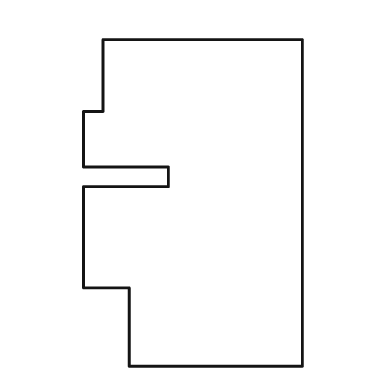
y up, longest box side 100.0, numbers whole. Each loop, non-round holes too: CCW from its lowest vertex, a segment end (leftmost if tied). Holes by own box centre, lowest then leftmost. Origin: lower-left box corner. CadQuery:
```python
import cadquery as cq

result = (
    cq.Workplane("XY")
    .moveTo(14.0, 0.0)
    .lineTo(67.0, 0.0)
    .lineTo(67.0, 100.0)
    .lineTo(6.0, 100.0)
    .lineTo(6.0, 78.0)
    .lineTo(0.0, 78.0)
    .lineTo(0.0, 61.0)
    .lineTo(26.0, 61.0)
    .lineTo(26.0, 55.0)
    .lineTo(0.0, 55.0)
    .lineTo(0.0, 24.0)
    .lineTo(14.0, 24.0)
    .close()
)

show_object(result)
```